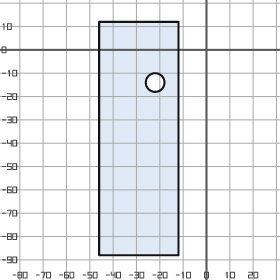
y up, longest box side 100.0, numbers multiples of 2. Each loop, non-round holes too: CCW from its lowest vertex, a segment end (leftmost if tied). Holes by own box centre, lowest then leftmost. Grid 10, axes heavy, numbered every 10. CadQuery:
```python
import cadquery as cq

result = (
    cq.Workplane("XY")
    .moveTo(-46.0, -88.0)
    .lineTo(-12.0, -88.0)
    .lineTo(-12.0, 12.0)
    .lineTo(-46.0, 12.0)
    .close()
    .moveTo(-22.0, -14.0)
    .circle(4.0)
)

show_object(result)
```